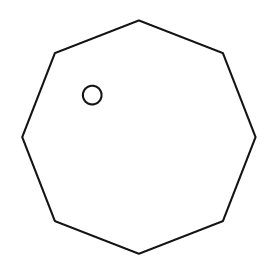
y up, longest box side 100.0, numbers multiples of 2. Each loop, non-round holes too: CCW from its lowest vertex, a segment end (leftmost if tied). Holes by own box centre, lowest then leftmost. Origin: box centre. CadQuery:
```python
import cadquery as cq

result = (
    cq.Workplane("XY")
    .moveTo(0.0, -50.0)
    .lineTo(36.0, -36.0)
    .lineTo(50.0, 0.0)
    .lineTo(36.0, 36.0)
    .lineTo(0.0, 50.0)
    .lineTo(-36.0, 36.0)
    .lineTo(-50.0, 0.0)
    .lineTo(-36.0, -36.0)
    .close()
    .moveTo(-20.0, 18.0)
    .circle(4.0)
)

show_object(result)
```